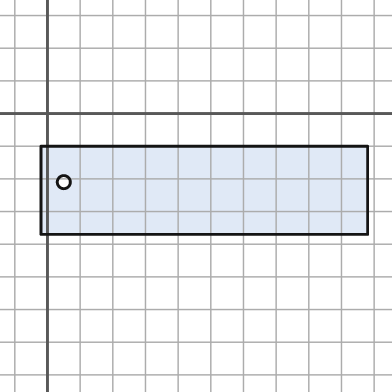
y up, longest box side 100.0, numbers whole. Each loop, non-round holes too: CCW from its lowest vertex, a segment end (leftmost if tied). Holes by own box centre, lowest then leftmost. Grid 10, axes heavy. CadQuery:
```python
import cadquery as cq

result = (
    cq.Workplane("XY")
    .moveTo(-2.0, -37.0)
    .lineTo(98.0, -37.0)
    .lineTo(98.0, -10.0)
    .lineTo(-2.0, -10.0)
    .close()
    .moveTo(5.0, -21.0)
    .circle(2.0)
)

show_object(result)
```